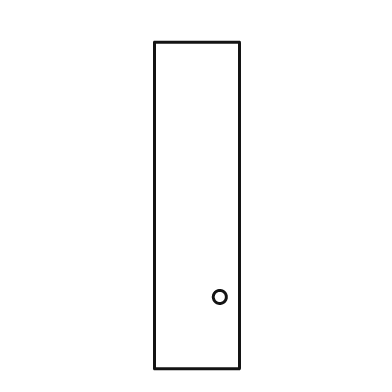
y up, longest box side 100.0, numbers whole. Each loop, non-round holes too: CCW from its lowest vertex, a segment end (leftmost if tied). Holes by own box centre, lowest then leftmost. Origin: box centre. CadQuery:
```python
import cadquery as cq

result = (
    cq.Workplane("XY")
    .moveTo(-13.0, -50.0)
    .lineTo(13.0, -50.0)
    .lineTo(13.0, 50.0)
    .lineTo(-13.0, 50.0)
    .close()
    .moveTo(7.0, -28.0)
    .circle(2.0)
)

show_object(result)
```